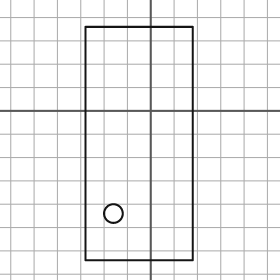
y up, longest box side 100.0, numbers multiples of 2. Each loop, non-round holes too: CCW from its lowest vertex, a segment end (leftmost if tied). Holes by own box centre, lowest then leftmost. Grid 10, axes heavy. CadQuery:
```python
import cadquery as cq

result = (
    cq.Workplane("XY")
    .moveTo(-28.0, -64.0)
    .lineTo(18.0, -64.0)
    .lineTo(18.0, 36.0)
    .lineTo(-28.0, 36.0)
    .close()
    .moveTo(-16.0, -44.0)
    .circle(4.0)
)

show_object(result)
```